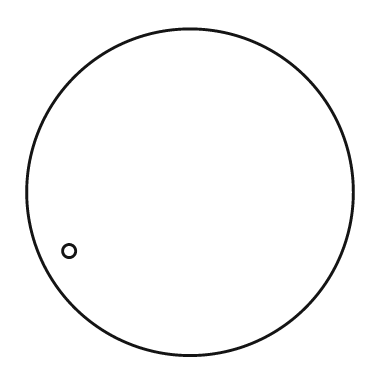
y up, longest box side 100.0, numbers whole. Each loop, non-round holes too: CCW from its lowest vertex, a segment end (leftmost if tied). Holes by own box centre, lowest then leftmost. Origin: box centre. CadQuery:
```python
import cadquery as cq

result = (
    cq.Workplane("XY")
    .moveTo(0.0, 0.0)
    .circle(50.0)
    .moveTo(-37.0, -18.0)
    .circle(2.0)
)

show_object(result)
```